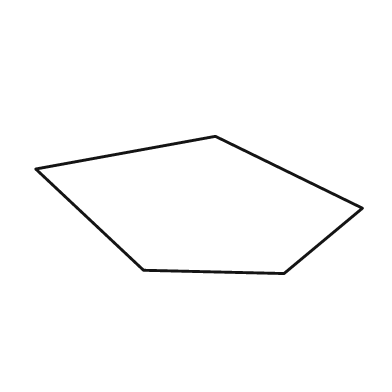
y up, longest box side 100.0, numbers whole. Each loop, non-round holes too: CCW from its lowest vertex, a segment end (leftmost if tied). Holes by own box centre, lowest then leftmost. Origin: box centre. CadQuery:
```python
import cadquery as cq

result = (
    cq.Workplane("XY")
    .moveTo(26.0, -21.0)
    .lineTo(50.0, -1.0)
    .lineTo(5.0, 21.0)
    .lineTo(-50.0, 11.0)
    .lineTo(-17.0, -20.0)
    .close()
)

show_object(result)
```